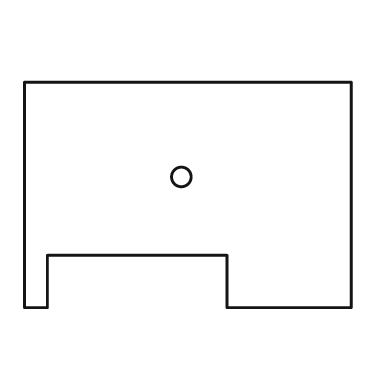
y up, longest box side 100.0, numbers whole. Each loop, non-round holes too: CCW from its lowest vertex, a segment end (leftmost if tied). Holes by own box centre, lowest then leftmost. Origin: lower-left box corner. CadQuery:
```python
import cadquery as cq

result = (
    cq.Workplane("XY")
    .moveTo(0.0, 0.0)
    .lineTo(7.0, 0.0)
    .lineTo(7.0, 16.0)
    .lineTo(62.0, 16.0)
    .lineTo(62.0, 0.0)
    .lineTo(100.0, 0.0)
    .lineTo(100.0, 69.0)
    .lineTo(0.0, 69.0)
    .close()
    .moveTo(48.0, 40.0)
    .circle(3.0)
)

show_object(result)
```